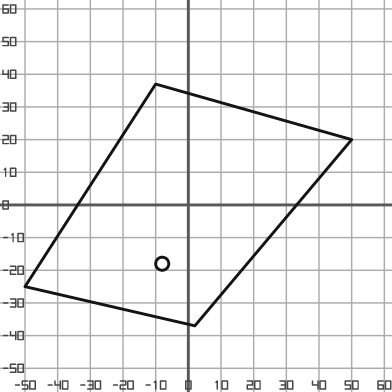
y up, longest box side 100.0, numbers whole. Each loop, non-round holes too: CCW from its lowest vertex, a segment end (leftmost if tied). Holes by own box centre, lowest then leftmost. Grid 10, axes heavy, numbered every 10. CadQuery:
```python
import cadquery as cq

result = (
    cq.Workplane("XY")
    .moveTo(2.0, -37.0)
    .lineTo(50.0, 20.0)
    .lineTo(-10.0, 37.0)
    .lineTo(-50.0, -25.0)
    .close()
    .moveTo(-8.0, -18.0)
    .circle(2.0)
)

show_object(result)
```